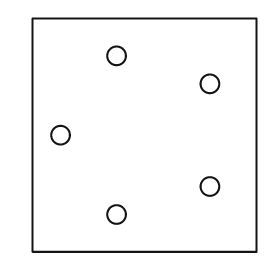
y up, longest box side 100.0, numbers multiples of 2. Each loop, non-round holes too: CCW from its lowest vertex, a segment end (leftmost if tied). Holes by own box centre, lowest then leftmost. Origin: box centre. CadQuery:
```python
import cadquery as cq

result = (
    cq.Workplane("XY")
    .moveTo(-48.0, -50.0)
    .lineTo(48.0, -50.0)
    .lineTo(48.0, 50.0)
    .lineTo(-48.0, 50.0)
    .close()
    .moveTo(-12.0, -34.0)
    .circle(4.0)
    .moveTo(28.0, -22.0)
    .circle(4.0)
    .moveTo(-36.0, 0.0)
    .circle(4.0)
    .moveTo(28.0, 22.0)
    .circle(4.0)
    .moveTo(-12.0, 34.0)
    .circle(4.0)
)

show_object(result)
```